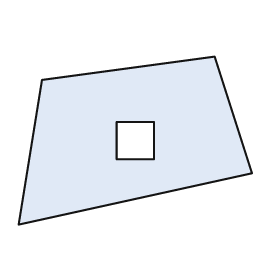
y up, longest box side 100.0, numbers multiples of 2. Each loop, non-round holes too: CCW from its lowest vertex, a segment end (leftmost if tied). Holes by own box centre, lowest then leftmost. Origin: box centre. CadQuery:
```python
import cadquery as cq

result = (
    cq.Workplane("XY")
    .moveTo(-50.0, -36.0)
    .lineTo(50.0, -14.0)
    .lineTo(34.0, 36.0)
    .lineTo(-40.0, 26.0)
    .close()
    .moveTo(-8.0, -8.0)
    .lineTo(8.0, -8.0)
    .lineTo(8.0, 8.0)
    .lineTo(-8.0, 8.0)
    .close()
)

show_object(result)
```